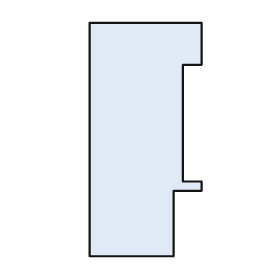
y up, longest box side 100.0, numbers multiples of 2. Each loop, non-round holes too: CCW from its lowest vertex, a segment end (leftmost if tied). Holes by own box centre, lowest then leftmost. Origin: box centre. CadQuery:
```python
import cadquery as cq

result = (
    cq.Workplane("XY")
    .moveTo(-24.0, -50.0)
    .lineTo(12.0, -50.0)
    .lineTo(12.0, -22.0)
    .lineTo(24.0, -22.0)
    .lineTo(24.0, -18.0)
    .lineTo(16.0, -18.0)
    .lineTo(16.0, 32.0)
    .lineTo(24.0, 32.0)
    .lineTo(24.0, 50.0)
    .lineTo(-24.0, 50.0)
    .close()
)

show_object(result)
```